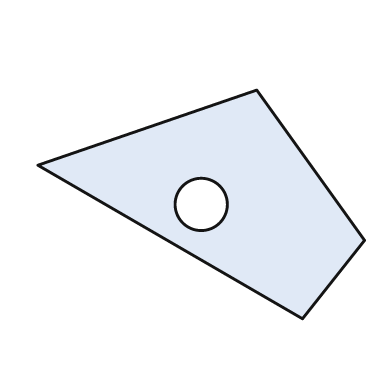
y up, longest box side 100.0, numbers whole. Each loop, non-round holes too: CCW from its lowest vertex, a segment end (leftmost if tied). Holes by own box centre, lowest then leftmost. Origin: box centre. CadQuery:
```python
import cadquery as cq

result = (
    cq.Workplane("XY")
    .moveTo(31.0, -35.0)
    .lineTo(50.0, -11.0)
    .lineTo(17.0, 35.0)
    .lineTo(-50.0, 12.0)
    .close()
    .moveTo(0.0, 0.0)
    .circle(8.0)
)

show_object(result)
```